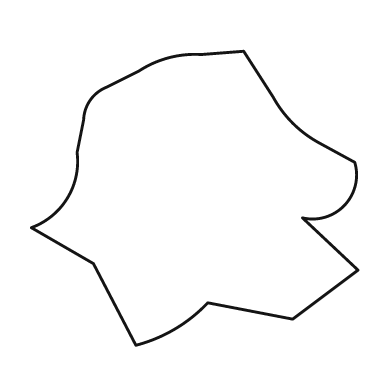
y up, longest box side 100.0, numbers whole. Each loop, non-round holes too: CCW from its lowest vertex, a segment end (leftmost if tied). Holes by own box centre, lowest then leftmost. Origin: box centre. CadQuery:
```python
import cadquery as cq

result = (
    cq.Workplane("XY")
    .moveTo(-18.0, -45.0)
    .threePointArc((-6.0, -40.0), (4.0, -32.0))
    .lineTo(30.0, -37.0)
    .lineTo(50.0, -22.0)
    .lineTo(33.0, -6.0)
    .threePointArc((46.0, -2.0), (49.0, 11.0))
    .lineTo(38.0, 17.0)
    .threePointArc((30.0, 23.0), (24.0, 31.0))
    .lineTo(15.0, 45.0)
    .lineTo(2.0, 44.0)
    .threePointArc((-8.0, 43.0), (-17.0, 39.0))
    .lineTo(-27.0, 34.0)
    .threePointArc((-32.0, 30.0), (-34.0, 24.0))
    .lineTo(-36.0, 14.0)
    .threePointArc((-39.0, 0.0), (-50.0, -9.0))
    .lineTo(-31.0, -20.0)
    .close()
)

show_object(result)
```